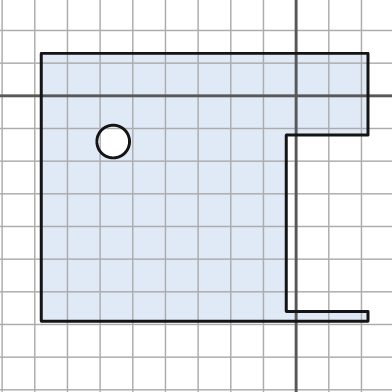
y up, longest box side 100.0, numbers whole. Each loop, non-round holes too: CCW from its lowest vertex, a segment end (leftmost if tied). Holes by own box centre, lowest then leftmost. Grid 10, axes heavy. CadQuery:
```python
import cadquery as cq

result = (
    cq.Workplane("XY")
    .moveTo(-78.0, -69.0)
    .lineTo(22.0, -69.0)
    .lineTo(22.0, -66.0)
    .lineTo(-3.0, -66.0)
    .lineTo(-3.0, -12.0)
    .lineTo(22.0, -12.0)
    .lineTo(22.0, 13.0)
    .lineTo(-78.0, 13.0)
    .close()
    .moveTo(-56.0, -14.0)
    .circle(5.0)
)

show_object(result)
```